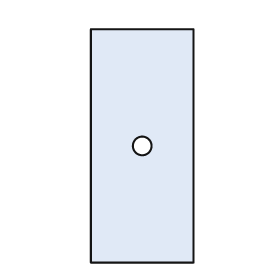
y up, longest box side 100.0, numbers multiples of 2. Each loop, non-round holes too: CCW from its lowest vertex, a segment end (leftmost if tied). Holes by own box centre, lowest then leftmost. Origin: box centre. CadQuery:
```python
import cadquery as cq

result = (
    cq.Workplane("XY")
    .moveTo(-22.0, -50.0)
    .lineTo(22.0, -50.0)
    .lineTo(22.0, 50.0)
    .lineTo(-22.0, 50.0)
    .close()
    .moveTo(0.0, 0.0)
    .circle(4.0)
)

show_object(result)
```